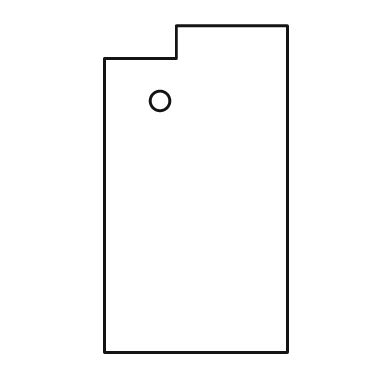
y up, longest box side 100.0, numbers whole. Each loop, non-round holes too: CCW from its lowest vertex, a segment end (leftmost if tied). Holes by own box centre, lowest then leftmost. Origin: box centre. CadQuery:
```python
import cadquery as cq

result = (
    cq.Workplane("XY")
    .moveTo(-28.0, -50.0)
    .lineTo(28.0, -50.0)
    .lineTo(28.0, 50.0)
    .lineTo(-6.0, 50.0)
    .lineTo(-6.0, 40.0)
    .lineTo(-28.0, 40.0)
    .close()
    .moveTo(-11.0, 27.0)
    .circle(3.0)
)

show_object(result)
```